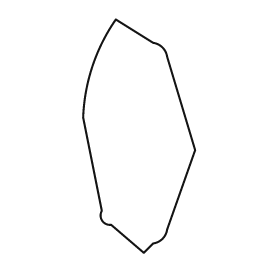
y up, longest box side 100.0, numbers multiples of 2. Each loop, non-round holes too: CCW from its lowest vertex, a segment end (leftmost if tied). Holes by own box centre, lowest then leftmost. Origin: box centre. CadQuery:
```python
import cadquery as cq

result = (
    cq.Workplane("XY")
    .moveTo(2.0, -50.0)
    .lineTo(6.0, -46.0)
    .threePointArc((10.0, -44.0), (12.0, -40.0))
    .lineTo(24.0, -6.0)
    .lineTo(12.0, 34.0)
    .threePointArc((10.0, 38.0), (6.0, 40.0))
    .lineTo(-10.0, 50.0)
    .threePointArc((-20.0, 30.0), (-24.0, 8.0))
    .lineTo(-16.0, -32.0)
    .threePointArc((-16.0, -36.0), (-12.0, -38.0))
    .close()
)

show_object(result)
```